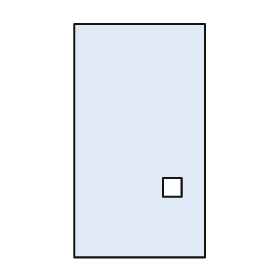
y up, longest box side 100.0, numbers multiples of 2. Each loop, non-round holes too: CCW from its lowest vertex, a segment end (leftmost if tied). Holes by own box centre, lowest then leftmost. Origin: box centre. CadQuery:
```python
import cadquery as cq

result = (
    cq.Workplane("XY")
    .moveTo(-28.0, -50.0)
    .lineTo(28.0, -50.0)
    .lineTo(28.0, 50.0)
    .lineTo(-28.0, 50.0)
    .close()
    .moveTo(10.0, -24.0)
    .lineTo(18.0, -24.0)
    .lineTo(18.0, -16.0)
    .lineTo(10.0, -16.0)
    .close()
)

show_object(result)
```